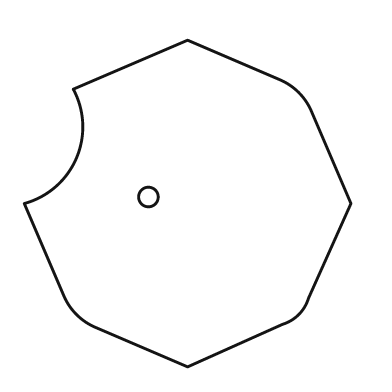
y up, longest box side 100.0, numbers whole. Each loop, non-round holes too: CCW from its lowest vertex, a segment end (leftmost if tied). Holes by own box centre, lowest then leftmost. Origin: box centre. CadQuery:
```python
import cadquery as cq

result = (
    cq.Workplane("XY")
    .moveTo(0.0, -50.0)
    .lineTo(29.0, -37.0)
    .threePointArc((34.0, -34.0), (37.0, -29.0))
    .lineTo(50.0, 0.0)
    .lineTo(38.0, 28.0)
    .threePointArc((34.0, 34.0), (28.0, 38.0))
    .lineTo(0.0, 50.0)
    .lineTo(-35.0, 35.0)
    .threePointArc((-34.0, 14.0), (-50.0, 0.0))
    .lineTo(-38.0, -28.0)
    .threePointArc((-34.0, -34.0), (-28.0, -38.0))
    .close()
    .moveTo(-12.0, 2.0)
    .circle(3.0)
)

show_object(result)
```